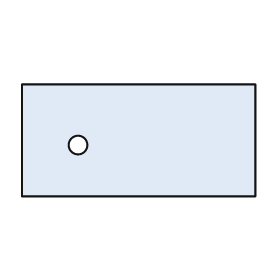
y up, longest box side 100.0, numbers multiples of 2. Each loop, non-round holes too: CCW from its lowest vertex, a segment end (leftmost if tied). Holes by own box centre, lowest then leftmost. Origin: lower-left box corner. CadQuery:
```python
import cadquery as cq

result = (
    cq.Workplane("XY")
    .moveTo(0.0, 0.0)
    .lineTo(100.0, 0.0)
    .lineTo(100.0, 48.0)
    .lineTo(0.0, 48.0)
    .close()
    .moveTo(24.0, 22.0)
    .circle(4.0)
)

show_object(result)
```